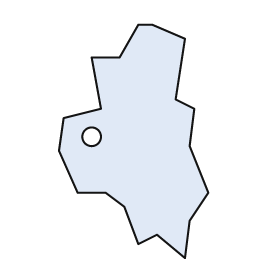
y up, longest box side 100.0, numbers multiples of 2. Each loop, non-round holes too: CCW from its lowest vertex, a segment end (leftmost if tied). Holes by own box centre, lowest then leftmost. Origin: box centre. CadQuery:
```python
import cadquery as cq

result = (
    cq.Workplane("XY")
    .moveTo(22.0, -50.0)
    .lineTo(24.0, -34.0)
    .lineTo(32.0, -22.0)
    .lineTo(24.0, -2.0)
    .lineTo(26.0, 14.0)
    .lineTo(18.0, 18.0)
    .lineTo(22.0, 44.0)
    .lineTo(8.0, 50.0)
    .lineTo(2.0, 50.0)
    .lineTo(-6.0, 36.0)
    .lineTo(-18.0, 36.0)
    .lineTo(-14.0, 14.0)
    .lineTo(-30.0, 10.0)
    .lineTo(-32.0, -4.0)
    .lineTo(-24.0, -22.0)
    .lineTo(-12.0, -22.0)
    .lineTo(-4.0, -28.0)
    .lineTo(2.0, -44.0)
    .lineTo(10.0, -40.0)
    .close()
    .moveTo(-18.0, 2.0)
    .circle(4.0)
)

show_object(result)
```